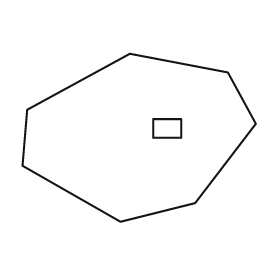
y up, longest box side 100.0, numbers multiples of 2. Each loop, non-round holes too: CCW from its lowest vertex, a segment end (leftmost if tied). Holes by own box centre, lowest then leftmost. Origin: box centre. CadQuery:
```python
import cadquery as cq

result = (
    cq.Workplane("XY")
    .moveTo(-8.0, -36.0)
    .lineTo(24.0, -28.0)
    .lineTo(50.0, 6.0)
    .lineTo(38.0, 28.0)
    .lineTo(-4.0, 36.0)
    .lineTo(-48.0, 12.0)
    .lineTo(-50.0, -12.0)
    .close()
    .moveTo(6.0, 0.0)
    .lineTo(18.0, 0.0)
    .lineTo(18.0, 8.0)
    .lineTo(6.0, 8.0)
    .close()
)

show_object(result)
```